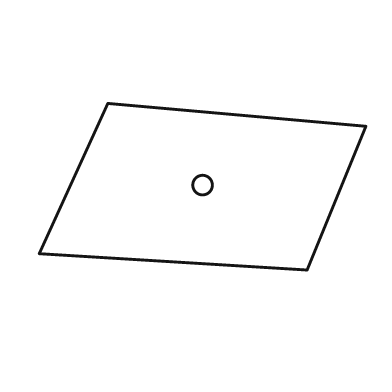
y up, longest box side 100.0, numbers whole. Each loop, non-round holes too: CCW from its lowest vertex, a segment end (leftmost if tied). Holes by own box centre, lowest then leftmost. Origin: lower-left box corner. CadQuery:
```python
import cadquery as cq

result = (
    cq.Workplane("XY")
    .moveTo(82.0, 0.0)
    .lineTo(100.0, 44.0)
    .lineTo(21.0, 51.0)
    .lineTo(0.0, 5.0)
    .close()
    .moveTo(50.0, 26.0)
    .circle(3.0)
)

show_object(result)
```